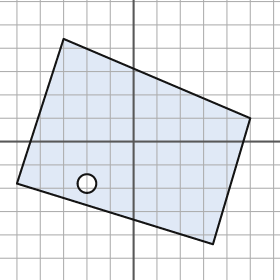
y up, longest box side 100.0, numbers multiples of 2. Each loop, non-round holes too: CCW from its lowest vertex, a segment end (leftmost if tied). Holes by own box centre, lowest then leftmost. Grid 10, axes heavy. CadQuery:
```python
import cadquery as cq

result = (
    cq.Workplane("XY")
    .moveTo(34.0, -44.0)
    .lineTo(50.0, 10.0)
    .lineTo(-30.0, 44.0)
    .lineTo(-50.0, -18.0)
    .close()
    .moveTo(-20.0, -18.0)
    .circle(4.0)
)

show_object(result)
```